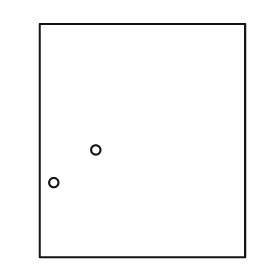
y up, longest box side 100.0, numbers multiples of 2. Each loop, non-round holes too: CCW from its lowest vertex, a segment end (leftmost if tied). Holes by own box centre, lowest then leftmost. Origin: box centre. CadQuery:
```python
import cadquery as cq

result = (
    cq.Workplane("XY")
    .moveTo(-44.0, -50.0)
    .lineTo(44.0, -50.0)
    .lineTo(44.0, 50.0)
    .lineTo(-44.0, 50.0)
    .close()
    .moveTo(-38.0, -18.0)
    .circle(2.0)
    .moveTo(-20.0, -4.0)
    .circle(2.0)
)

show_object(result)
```